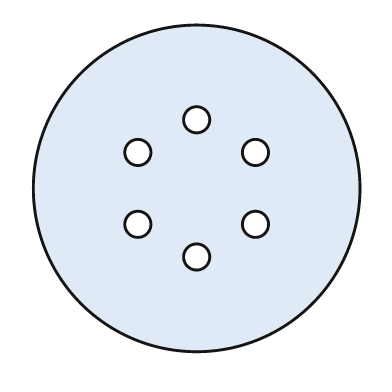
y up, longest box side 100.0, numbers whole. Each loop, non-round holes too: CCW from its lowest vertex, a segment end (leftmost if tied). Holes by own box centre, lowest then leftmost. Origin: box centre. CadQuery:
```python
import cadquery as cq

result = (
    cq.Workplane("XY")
    .moveTo(0.0, 0.0)
    .circle(50.0)
    .moveTo(0.0, -21.0)
    .circle(4.0)
    .moveTo(-18.0, -11.0)
    .circle(4.0)
    .moveTo(18.0, -11.0)
    .circle(4.0)
    .moveTo(-18.0, 11.0)
    .circle(4.0)
    .moveTo(18.0, 11.0)
    .circle(4.0)
    .moveTo(0.0, 21.0)
    .circle(4.0)
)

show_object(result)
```